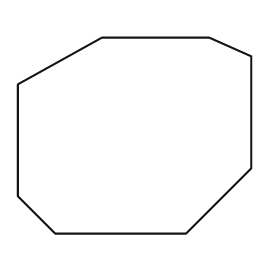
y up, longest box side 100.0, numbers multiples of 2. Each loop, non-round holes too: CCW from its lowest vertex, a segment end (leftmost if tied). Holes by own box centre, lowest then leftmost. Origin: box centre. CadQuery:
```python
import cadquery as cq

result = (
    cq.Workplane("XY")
    .moveTo(-34.0, -42.0)
    .lineTo(22.0, -42.0)
    .lineTo(50.0, -14.0)
    .lineTo(50.0, 34.0)
    .lineTo(32.0, 42.0)
    .lineTo(-14.0, 42.0)
    .lineTo(-50.0, 22.0)
    .lineTo(-50.0, -26.0)
    .close()
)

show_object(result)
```